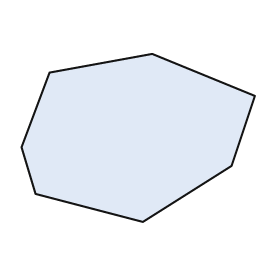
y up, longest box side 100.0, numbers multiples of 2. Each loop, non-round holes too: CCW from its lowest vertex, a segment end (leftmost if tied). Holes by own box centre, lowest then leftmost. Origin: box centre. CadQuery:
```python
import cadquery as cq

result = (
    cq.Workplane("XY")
    .moveTo(2.0, -36.0)
    .lineTo(40.0, -12.0)
    .lineTo(50.0, 18.0)
    .lineTo(6.0, 36.0)
    .lineTo(-38.0, 28.0)
    .lineTo(-50.0, -4.0)
    .lineTo(-44.0, -24.0)
    .close()
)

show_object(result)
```